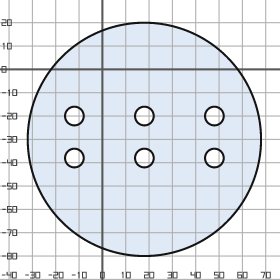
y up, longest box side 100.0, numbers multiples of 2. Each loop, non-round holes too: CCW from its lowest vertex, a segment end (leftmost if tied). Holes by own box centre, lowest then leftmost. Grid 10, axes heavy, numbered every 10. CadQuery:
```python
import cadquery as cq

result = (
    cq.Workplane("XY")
    .moveTo(18.0, -30.0)
    .circle(50.0)
    .moveTo(-12.0, -38.0)
    .circle(4.0)
    .moveTo(18.0, -38.0)
    .circle(4.0)
    .moveTo(48.0, -38.0)
    .circle(4.0)
    .moveTo(-12.0, -20.0)
    .circle(4.0)
    .moveTo(18.0, -20.0)
    .circle(4.0)
    .moveTo(48.0, -20.0)
    .circle(4.0)
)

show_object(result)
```